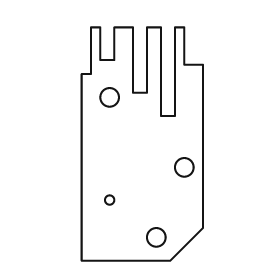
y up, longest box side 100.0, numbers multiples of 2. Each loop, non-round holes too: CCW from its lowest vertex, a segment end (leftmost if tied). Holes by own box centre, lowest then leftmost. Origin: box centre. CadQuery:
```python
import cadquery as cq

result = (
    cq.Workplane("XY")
    .moveTo(-26.0, -50.0)
    .lineTo(12.0, -50.0)
    .lineTo(26.0, -36.0)
    .lineTo(26.0, 34.0)
    .lineTo(18.0, 34.0)
    .lineTo(18.0, 50.0)
    .lineTo(14.0, 50.0)
    .lineTo(14.0, 12.0)
    .lineTo(8.0, 12.0)
    .lineTo(8.0, 50.0)
    .lineTo(2.0, 50.0)
    .lineTo(2.0, 22.0)
    .lineTo(-4.0, 22.0)
    .lineTo(-4.0, 50.0)
    .lineTo(-12.0, 50.0)
    .lineTo(-12.0, 36.0)
    .lineTo(-18.0, 36.0)
    .lineTo(-18.0, 50.0)
    .lineTo(-22.0, 50.0)
    .lineTo(-22.0, 30.0)
    .lineTo(-26.0, 30.0)
    .close()
    .moveTo(6.0, -40.0)
    .circle(4.0)
    .moveTo(-14.0, -24.0)
    .circle(2.0)
    .moveTo(18.0, -10.0)
    .circle(4.0)
    .moveTo(-14.0, 20.0)
    .circle(4.0)
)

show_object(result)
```